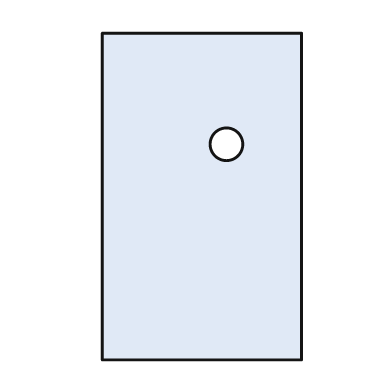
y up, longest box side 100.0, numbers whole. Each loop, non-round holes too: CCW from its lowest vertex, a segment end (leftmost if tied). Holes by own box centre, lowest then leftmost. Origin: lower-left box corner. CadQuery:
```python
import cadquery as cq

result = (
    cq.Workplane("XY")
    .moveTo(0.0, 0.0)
    .lineTo(61.0, 0.0)
    .lineTo(61.0, 100.0)
    .lineTo(0.0, 100.0)
    .close()
    .moveTo(38.0, 66.0)
    .circle(5.0)
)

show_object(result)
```